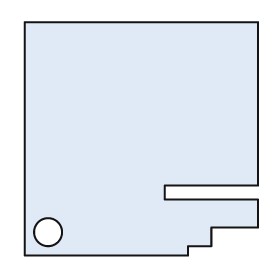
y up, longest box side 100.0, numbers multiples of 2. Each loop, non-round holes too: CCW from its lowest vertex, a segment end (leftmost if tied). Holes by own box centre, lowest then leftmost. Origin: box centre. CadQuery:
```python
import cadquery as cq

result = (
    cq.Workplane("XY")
    .moveTo(-50.0, -50.0)
    .lineTo(20.0, -50.0)
    .lineTo(20.0, -46.0)
    .lineTo(30.0, -46.0)
    .lineTo(30.0, -38.0)
    .lineTo(50.0, -38.0)
    .lineTo(50.0, -26.0)
    .lineTo(10.0, -26.0)
    .lineTo(10.0, -20.0)
    .lineTo(50.0, -20.0)
    .lineTo(50.0, 50.0)
    .lineTo(-50.0, 50.0)
    .close()
    .moveTo(-40.0, -40.0)
    .circle(6.0)
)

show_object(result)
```